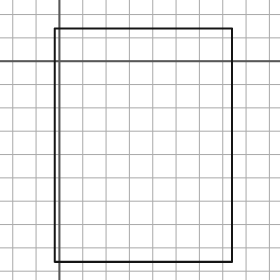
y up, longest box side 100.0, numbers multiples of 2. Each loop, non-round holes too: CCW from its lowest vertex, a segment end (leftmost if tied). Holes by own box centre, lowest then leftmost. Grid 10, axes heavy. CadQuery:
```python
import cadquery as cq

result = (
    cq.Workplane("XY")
    .moveTo(-2.0, -86.0)
    .lineTo(74.0, -86.0)
    .lineTo(74.0, 14.0)
    .lineTo(-2.0, 14.0)
    .close()
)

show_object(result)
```